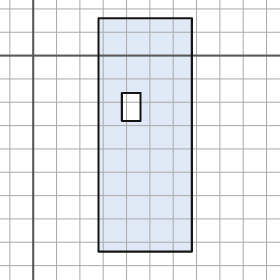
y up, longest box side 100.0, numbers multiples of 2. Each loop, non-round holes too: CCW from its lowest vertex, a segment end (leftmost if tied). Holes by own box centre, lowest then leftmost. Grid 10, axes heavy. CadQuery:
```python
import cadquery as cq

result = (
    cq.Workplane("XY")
    .moveTo(28.0, -84.0)
    .lineTo(68.0, -84.0)
    .lineTo(68.0, 16.0)
    .lineTo(28.0, 16.0)
    .close()
    .moveTo(38.0, -28.0)
    .lineTo(46.0, -28.0)
    .lineTo(46.0, -16.0)
    .lineTo(38.0, -16.0)
    .close()
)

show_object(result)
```